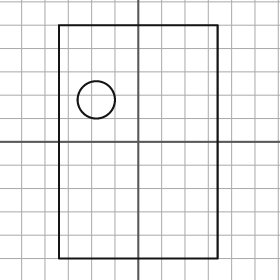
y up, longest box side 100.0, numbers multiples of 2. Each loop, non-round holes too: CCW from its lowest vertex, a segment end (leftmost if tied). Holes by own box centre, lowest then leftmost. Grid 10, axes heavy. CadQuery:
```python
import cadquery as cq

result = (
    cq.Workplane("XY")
    .moveTo(-34.0, -50.0)
    .lineTo(34.0, -50.0)
    .lineTo(34.0, 50.0)
    .lineTo(-34.0, 50.0)
    .close()
    .moveTo(-18.0, 18.0)
    .circle(8.0)
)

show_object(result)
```